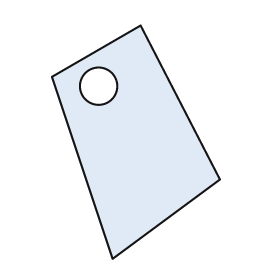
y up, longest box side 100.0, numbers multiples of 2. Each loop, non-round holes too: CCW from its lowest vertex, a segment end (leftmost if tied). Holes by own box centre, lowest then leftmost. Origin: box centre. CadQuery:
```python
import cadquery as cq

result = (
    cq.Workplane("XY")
    .moveTo(-10.0, -50.0)
    .lineTo(36.0, -16.0)
    .lineTo(2.0, 50.0)
    .lineTo(-36.0, 28.0)
    .close()
    .moveTo(-16.0, 24.0)
    .circle(8.0)
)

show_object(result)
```